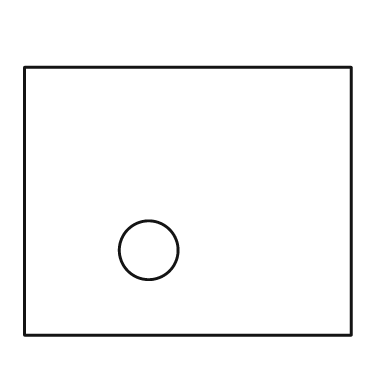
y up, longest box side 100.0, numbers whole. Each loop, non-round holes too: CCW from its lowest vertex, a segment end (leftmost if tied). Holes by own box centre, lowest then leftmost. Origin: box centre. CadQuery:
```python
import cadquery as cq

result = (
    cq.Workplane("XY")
    .moveTo(-50.0, -41.0)
    .lineTo(50.0, -41.0)
    .lineTo(50.0, 41.0)
    .lineTo(-50.0, 41.0)
    .close()
    .moveTo(-12.0, -15.0)
    .circle(9.0)
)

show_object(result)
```